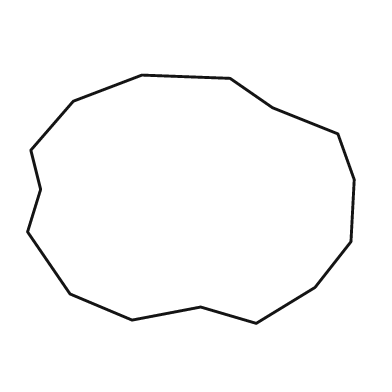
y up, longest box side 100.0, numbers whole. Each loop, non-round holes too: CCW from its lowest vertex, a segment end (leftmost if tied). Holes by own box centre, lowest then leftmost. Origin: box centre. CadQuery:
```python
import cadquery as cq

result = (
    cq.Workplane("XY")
    .moveTo(20.0, -38.0)
    .lineTo(38.0, -27.0)
    .lineTo(49.0, -13.0)
    .lineTo(50.0, 6.0)
    .lineTo(45.0, 20.0)
    .lineTo(25.0, 28.0)
    .lineTo(12.0, 37.0)
    .lineTo(-15.0, 38.0)
    .lineTo(-36.0, 30.0)
    .lineTo(-49.0, 15.0)
    .lineTo(-46.0, 3.0)
    .lineTo(-50.0, -10.0)
    .lineTo(-37.0, -29.0)
    .lineTo(-18.0, -37.0)
    .lineTo(3.0, -33.0)
    .close()
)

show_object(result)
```